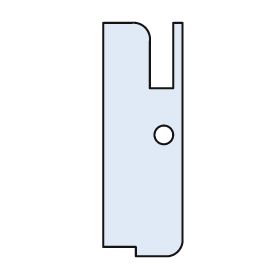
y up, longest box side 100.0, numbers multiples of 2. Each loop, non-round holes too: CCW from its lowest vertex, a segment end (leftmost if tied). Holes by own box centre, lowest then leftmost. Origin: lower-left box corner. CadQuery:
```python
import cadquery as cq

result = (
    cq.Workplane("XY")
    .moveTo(14.0, 0.0)
    .lineTo(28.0, 0.0)
    .threePointArc((32.0, 2.0), (34.0, 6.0))
    .lineTo(34.0, 100.0)
    .lineTo(30.0, 100.0)
    .lineTo(30.0, 72.0)
    .lineTo(20.0, 72.0)
    .lineTo(20.0, 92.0)
    .threePointArc((18.0, 98.0), (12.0, 100.0))
    .lineTo(0.0, 100.0)
    .lineTo(0.0, 4.0)
    .lineTo(14.0, 4.0)
    .close()
    .moveTo(26.0, 52.0)
    .circle(4.0)
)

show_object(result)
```